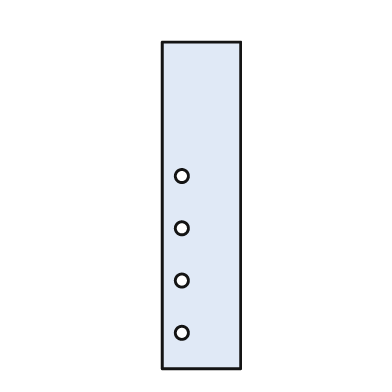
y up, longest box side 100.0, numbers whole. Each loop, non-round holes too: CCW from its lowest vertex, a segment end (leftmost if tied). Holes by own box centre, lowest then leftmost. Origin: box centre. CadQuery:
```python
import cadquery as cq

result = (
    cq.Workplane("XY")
    .moveTo(-12.0, -50.0)
    .lineTo(12.0, -50.0)
    .lineTo(12.0, 50.0)
    .lineTo(-12.0, 50.0)
    .close()
    .moveTo(-6.0, -39.0)
    .circle(2.0)
    .moveTo(-6.0, -23.0)
    .circle(2.0)
    .moveTo(-6.0, -7.0)
    .circle(2.0)
    .moveTo(-6.0, 9.0)
    .circle(2.0)
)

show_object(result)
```